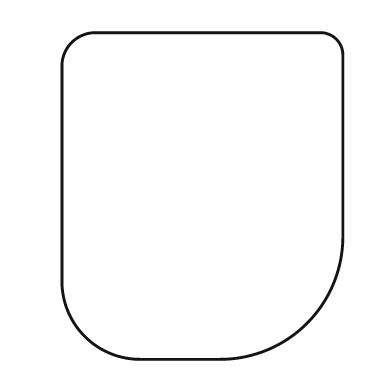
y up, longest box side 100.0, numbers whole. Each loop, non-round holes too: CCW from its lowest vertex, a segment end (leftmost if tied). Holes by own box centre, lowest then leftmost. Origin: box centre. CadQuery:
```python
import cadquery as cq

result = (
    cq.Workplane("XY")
    .moveTo(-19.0, -50.0)
    .lineTo(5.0, -50.0)
    .threePointArc((32.0, -39.0), (43.0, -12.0))
    .lineTo(43.0, 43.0)
    .threePointArc((41.0, 48.0), (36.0, 50.0))
    .lineTo(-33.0, 50.0)
    .threePointArc((-40.0, 47.0), (-43.0, 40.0))
    .lineTo(-43.0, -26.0)
    .threePointArc((-36.0, -43.0), (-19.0, -50.0))
    .close()
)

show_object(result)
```